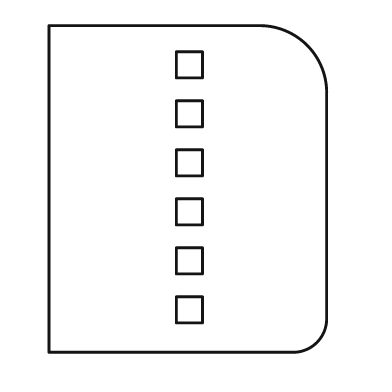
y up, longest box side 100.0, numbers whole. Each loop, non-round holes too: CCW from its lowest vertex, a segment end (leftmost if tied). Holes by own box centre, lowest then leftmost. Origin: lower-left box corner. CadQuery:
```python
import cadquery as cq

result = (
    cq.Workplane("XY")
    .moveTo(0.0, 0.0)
    .lineTo(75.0, 0.0)
    .threePointArc((82.0, 3.0), (85.0, 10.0))
    .lineTo(85.0, 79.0)
    .threePointArc((79.0, 94.0), (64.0, 100.0))
    .lineTo(0.0, 100.0)
    .close()
    .moveTo(39.0, 9.0)
    .lineTo(47.0, 9.0)
    .lineTo(47.0, 17.0)
    .lineTo(39.0, 17.0)
    .close()
    .moveTo(39.0, 24.0)
    .lineTo(47.0, 24.0)
    .lineTo(47.0, 32.0)
    .lineTo(39.0, 32.0)
    .close()
    .moveTo(39.0, 39.0)
    .lineTo(47.0, 39.0)
    .lineTo(47.0, 47.0)
    .lineTo(39.0, 47.0)
    .close()
    .moveTo(39.0, 54.0)
    .lineTo(47.0, 54.0)
    .lineTo(47.0, 62.0)
    .lineTo(39.0, 62.0)
    .close()
    .moveTo(39.0, 69.0)
    .lineTo(47.0, 69.0)
    .lineTo(47.0, 77.0)
    .lineTo(39.0, 77.0)
    .close()
    .moveTo(39.0, 84.0)
    .lineTo(47.0, 84.0)
    .lineTo(47.0, 92.0)
    .lineTo(39.0, 92.0)
    .close()
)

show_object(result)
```